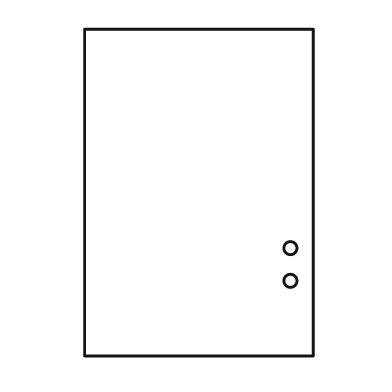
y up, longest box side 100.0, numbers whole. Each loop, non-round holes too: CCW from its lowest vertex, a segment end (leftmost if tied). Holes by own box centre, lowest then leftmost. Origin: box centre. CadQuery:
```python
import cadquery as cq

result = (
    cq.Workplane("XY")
    .moveTo(-35.0, -50.0)
    .lineTo(35.0, -50.0)
    .lineTo(35.0, 50.0)
    .lineTo(-35.0, 50.0)
    .close()
    .moveTo(28.0, -27.0)
    .circle(2.0)
    .moveTo(28.0, -17.0)
    .circle(2.0)
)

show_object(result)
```